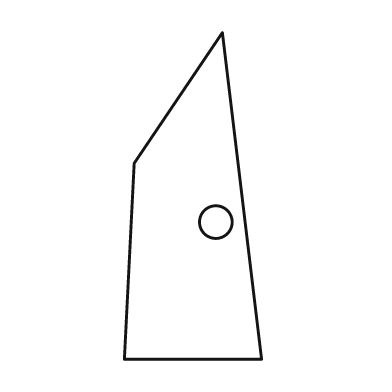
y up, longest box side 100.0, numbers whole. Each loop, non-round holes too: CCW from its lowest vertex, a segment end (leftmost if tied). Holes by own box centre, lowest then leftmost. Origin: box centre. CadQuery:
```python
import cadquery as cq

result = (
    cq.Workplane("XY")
    .moveTo(-21.0, -50.0)
    .lineTo(21.0, -50.0)
    .lineTo(9.0, 50.0)
    .lineTo(-18.0, 10.0)
    .close()
    .moveTo(7.0, -8.0)
    .circle(5.0)
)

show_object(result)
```